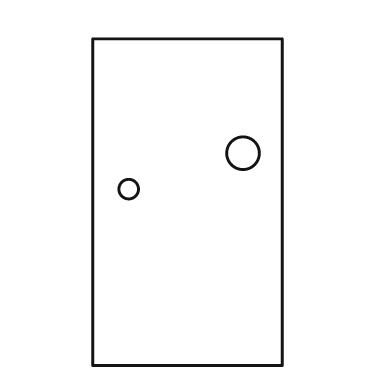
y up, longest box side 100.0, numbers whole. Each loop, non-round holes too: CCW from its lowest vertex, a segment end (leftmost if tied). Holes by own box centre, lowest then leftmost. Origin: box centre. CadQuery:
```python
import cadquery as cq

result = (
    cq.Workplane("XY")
    .moveTo(-29.0, -50.0)
    .lineTo(29.0, -50.0)
    .lineTo(29.0, 50.0)
    .lineTo(-29.0, 50.0)
    .close()
    .moveTo(-18.0, 4.0)
    .circle(3.0)
    .moveTo(17.0, 15.0)
    .circle(5.0)
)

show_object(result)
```